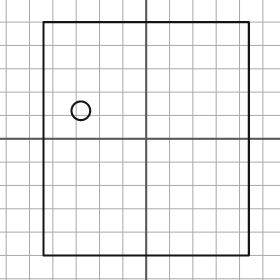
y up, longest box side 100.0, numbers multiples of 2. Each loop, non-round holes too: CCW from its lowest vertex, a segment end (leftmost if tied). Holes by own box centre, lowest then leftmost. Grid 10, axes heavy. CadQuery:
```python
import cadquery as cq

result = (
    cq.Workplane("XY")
    .moveTo(-44.0, -50.0)
    .lineTo(44.0, -50.0)
    .lineTo(44.0, 50.0)
    .lineTo(-44.0, 50.0)
    .close()
    .moveTo(-28.0, 12.0)
    .circle(4.0)
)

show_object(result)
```